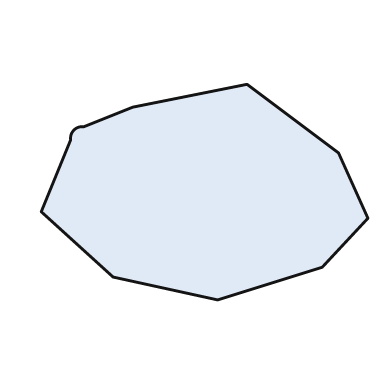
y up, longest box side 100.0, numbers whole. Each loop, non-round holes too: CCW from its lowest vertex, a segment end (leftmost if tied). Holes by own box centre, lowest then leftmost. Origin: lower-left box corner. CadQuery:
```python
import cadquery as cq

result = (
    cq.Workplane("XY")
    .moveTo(54.0, 0.0)
    .lineTo(86.0, 10.0)
    .lineTo(100.0, 25.0)
    .lineTo(91.0, 45.0)
    .lineTo(63.0, 66.0)
    .lineTo(28.0, 59.0)
    .lineTo(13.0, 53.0)
    .threePointArc((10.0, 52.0), (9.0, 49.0))
    .lineTo(0.0, 27.0)
    .lineTo(22.0, 7.0)
    .close()
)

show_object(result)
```